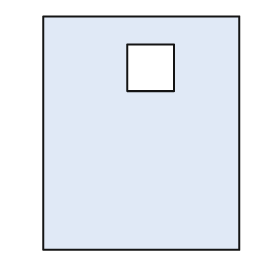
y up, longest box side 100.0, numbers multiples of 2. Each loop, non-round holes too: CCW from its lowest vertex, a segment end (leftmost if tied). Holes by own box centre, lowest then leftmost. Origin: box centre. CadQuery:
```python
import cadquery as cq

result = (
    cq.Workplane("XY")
    .moveTo(-42.0, -50.0)
    .lineTo(42.0, -50.0)
    .lineTo(42.0, 50.0)
    .lineTo(-42.0, 50.0)
    .close()
    .moveTo(-6.0, 18.0)
    .lineTo(14.0, 18.0)
    .lineTo(14.0, 38.0)
    .lineTo(-6.0, 38.0)
    .close()
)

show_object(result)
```